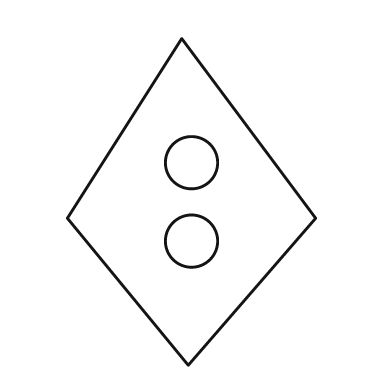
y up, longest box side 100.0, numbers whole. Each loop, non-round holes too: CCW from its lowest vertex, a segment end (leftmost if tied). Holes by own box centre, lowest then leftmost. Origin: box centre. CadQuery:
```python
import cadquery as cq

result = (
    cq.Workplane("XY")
    .moveTo(-1.0, -50.0)
    .lineTo(38.0, -5.0)
    .lineTo(-3.0, 50.0)
    .lineTo(-38.0, -5.0)
    .close()
    .moveTo(0.0, -12.0)
    .circle(8.0)
    .moveTo(0.0, 12.0)
    .circle(8.0)
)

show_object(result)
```